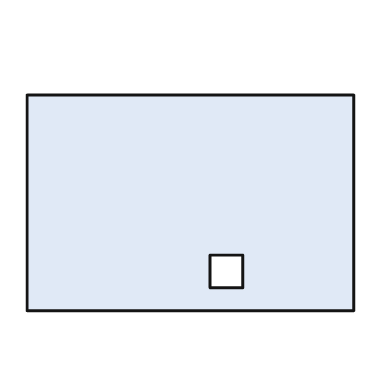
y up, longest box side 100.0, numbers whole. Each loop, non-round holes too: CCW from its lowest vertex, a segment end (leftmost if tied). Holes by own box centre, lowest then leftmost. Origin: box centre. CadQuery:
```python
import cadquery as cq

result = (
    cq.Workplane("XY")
    .moveTo(-50.0, -33.0)
    .lineTo(50.0, -33.0)
    .lineTo(50.0, 33.0)
    .lineTo(-50.0, 33.0)
    .close()
    .moveTo(6.0, -26.0)
    .lineTo(16.0, -26.0)
    .lineTo(16.0, -16.0)
    .lineTo(6.0, -16.0)
    .close()
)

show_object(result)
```